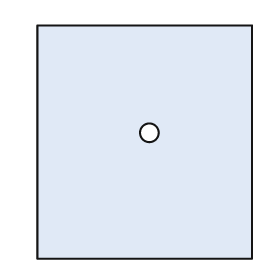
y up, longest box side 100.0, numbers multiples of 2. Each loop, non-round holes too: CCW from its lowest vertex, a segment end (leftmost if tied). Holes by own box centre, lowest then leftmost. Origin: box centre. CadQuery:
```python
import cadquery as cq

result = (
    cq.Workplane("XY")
    .moveTo(-46.0, -50.0)
    .lineTo(46.0, -50.0)
    .lineTo(46.0, 50.0)
    .lineTo(-46.0, 50.0)
    .close()
    .moveTo(2.0, 4.0)
    .circle(4.0)
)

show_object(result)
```